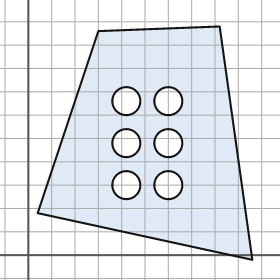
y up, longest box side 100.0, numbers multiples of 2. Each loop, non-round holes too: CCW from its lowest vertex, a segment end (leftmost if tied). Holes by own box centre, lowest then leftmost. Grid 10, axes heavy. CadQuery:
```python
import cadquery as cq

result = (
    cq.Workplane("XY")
    .moveTo(96.0, -2.0)
    .lineTo(82.0, 98.0)
    .lineTo(30.0, 96.0)
    .lineTo(4.0, 18.0)
    .close()
    .moveTo(42.0, 30.0)
    .circle(6.0)
    .moveTo(60.0, 30.0)
    .circle(6.0)
    .moveTo(42.0, 48.0)
    .circle(6.0)
    .moveTo(60.0, 48.0)
    .circle(6.0)
    .moveTo(42.0, 66.0)
    .circle(6.0)
    .moveTo(60.0, 66.0)
    .circle(6.0)
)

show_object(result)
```